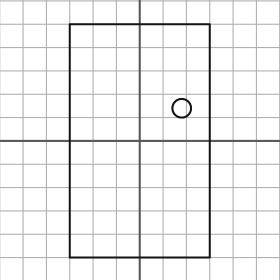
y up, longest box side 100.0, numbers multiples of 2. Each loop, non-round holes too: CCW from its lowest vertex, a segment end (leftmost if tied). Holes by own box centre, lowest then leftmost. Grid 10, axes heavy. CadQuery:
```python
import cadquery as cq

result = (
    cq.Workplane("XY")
    .moveTo(-30.0, -50.0)
    .lineTo(30.0, -50.0)
    .lineTo(30.0, 50.0)
    .lineTo(-30.0, 50.0)
    .close()
    .moveTo(18.0, 14.0)
    .circle(4.0)
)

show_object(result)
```